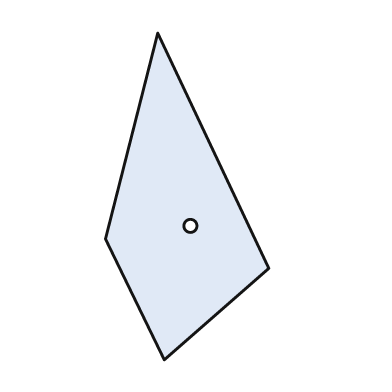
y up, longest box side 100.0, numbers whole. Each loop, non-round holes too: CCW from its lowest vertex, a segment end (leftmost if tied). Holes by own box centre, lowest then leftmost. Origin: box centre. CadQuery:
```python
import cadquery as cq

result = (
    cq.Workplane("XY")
    .moveTo(-7.0, -50.0)
    .lineTo(25.0, -22.0)
    .lineTo(-9.0, 50.0)
    .lineTo(-25.0, -13.0)
    .close()
    .moveTo(1.0, -9.0)
    .circle(2.0)
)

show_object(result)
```